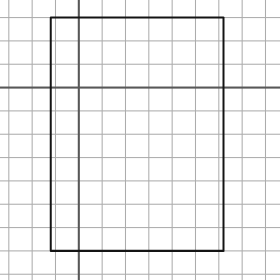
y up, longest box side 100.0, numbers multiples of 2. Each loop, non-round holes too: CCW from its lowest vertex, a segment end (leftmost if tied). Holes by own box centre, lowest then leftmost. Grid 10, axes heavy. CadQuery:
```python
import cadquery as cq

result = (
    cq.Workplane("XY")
    .moveTo(-12.0, -70.0)
    .lineTo(62.0, -70.0)
    .lineTo(62.0, 30.0)
    .lineTo(-12.0, 30.0)
    .close()
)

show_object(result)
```